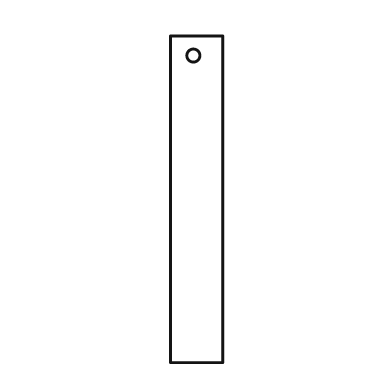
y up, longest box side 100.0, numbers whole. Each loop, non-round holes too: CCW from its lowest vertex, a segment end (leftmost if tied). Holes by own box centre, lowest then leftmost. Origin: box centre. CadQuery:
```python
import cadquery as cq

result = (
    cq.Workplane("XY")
    .moveTo(-8.0, -50.0)
    .lineTo(8.0, -50.0)
    .lineTo(8.0, 50.0)
    .lineTo(-8.0, 50.0)
    .close()
    .moveTo(-1.0, 44.0)
    .circle(2.0)
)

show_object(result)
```